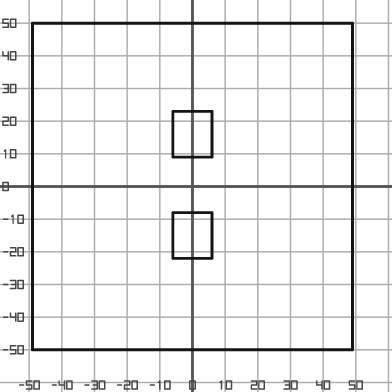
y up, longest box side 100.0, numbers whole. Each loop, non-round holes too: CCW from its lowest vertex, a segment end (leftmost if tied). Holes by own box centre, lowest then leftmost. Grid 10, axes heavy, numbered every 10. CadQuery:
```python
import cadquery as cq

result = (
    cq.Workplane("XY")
    .moveTo(-49.0, -50.0)
    .lineTo(49.0, -50.0)
    .lineTo(49.0, 50.0)
    .lineTo(-49.0, 50.0)
    .close()
    .moveTo(-6.0, -22.0)
    .lineTo(6.0, -22.0)
    .lineTo(6.0, -8.0)
    .lineTo(-6.0, -8.0)
    .close()
    .moveTo(-6.0, 9.0)
    .lineTo(6.0, 9.0)
    .lineTo(6.0, 23.0)
    .lineTo(-6.0, 23.0)
    .close()
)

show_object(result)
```